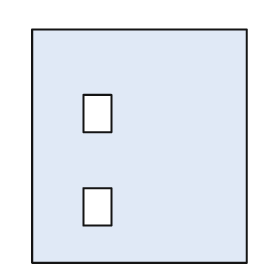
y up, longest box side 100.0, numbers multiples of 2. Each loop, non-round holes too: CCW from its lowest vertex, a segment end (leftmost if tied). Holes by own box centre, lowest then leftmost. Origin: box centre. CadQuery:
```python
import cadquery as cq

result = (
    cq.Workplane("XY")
    .moveTo(-46.0, -50.0)
    .lineTo(46.0, -50.0)
    .lineTo(46.0, 50.0)
    .lineTo(-46.0, 50.0)
    .close()
    .moveTo(-24.0, -34.0)
    .lineTo(-12.0, -34.0)
    .lineTo(-12.0, -18.0)
    .lineTo(-24.0, -18.0)
    .close()
    .moveTo(-24.0, 6.0)
    .lineTo(-12.0, 6.0)
    .lineTo(-12.0, 22.0)
    .lineTo(-24.0, 22.0)
    .close()
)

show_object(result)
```